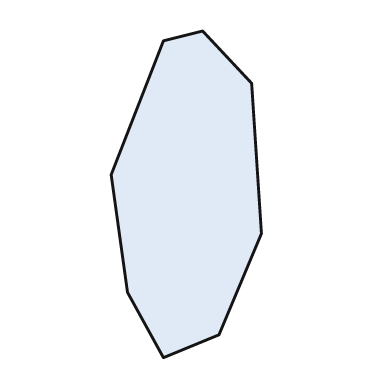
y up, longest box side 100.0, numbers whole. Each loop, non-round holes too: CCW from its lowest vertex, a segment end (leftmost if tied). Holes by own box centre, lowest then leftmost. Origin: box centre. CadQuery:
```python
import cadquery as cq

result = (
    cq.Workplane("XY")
    .moveTo(-7.0, -50.0)
    .lineTo(10.0, -43.0)
    .lineTo(23.0, -12.0)
    .lineTo(20.0, 34.0)
    .lineTo(5.0, 50.0)
    .lineTo(-7.0, 47.0)
    .lineTo(-23.0, 6.0)
    .lineTo(-18.0, -30.0)
    .close()
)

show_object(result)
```